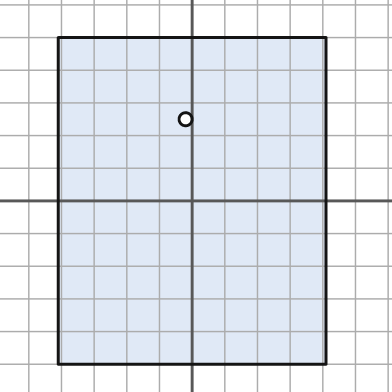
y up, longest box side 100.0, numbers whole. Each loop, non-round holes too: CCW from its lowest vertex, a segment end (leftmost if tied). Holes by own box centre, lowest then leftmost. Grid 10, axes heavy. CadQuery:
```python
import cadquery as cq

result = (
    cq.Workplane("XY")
    .moveTo(-41.0, -50.0)
    .lineTo(41.0, -50.0)
    .lineTo(41.0, 50.0)
    .lineTo(-41.0, 50.0)
    .close()
    .moveTo(-2.0, 25.0)
    .circle(2.0)
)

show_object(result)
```